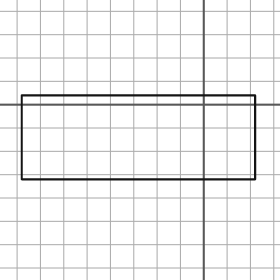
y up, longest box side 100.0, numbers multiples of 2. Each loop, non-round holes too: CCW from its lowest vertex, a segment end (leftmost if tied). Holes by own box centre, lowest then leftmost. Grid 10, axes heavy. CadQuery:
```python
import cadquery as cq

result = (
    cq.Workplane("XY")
    .moveTo(-78.0, -32.0)
    .lineTo(22.0, -32.0)
    .lineTo(22.0, 4.0)
    .lineTo(-78.0, 4.0)
    .close()
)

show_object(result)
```